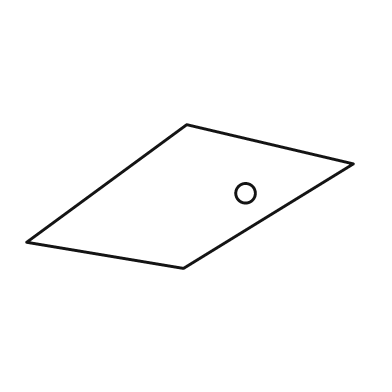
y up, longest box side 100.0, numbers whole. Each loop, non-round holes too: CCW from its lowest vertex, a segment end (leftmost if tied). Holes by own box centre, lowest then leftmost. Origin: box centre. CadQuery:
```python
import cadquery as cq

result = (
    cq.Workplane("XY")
    .moveTo(-2.0, -22.0)
    .lineTo(50.0, 10.0)
    .lineTo(-1.0, 22.0)
    .lineTo(-50.0, -14.0)
    .close()
    .moveTo(17.0, 1.0)
    .circle(3.0)
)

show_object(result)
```